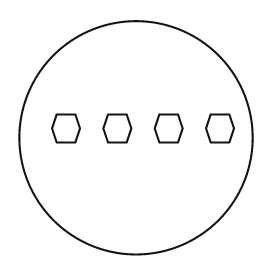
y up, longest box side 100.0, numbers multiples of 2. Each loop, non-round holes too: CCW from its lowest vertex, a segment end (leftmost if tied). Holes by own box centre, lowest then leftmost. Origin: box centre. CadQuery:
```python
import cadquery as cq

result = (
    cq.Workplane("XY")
    .moveTo(0.0, 0.0)
    .circle(50.0)
    .moveTo(-34.0, -2.0)
    .lineTo(-26.0, -2.0)
    .lineTo(-24.0, 4.0)
    .lineTo(-26.0, 10.0)
    .lineTo(-34.0, 10.0)
    .lineTo(-36.0, 4.0)
    .close()
    .moveTo(-12.0, -2.0)
    .lineTo(-4.0, -2.0)
    .lineTo(-2.0, 4.0)
    .lineTo(-4.0, 10.0)
    .lineTo(-12.0, 10.0)
    .lineTo(-14.0, 4.0)
    .close()
    .moveTo(10.0, -2.0)
    .lineTo(18.0, -2.0)
    .lineTo(20.0, 4.0)
    .lineTo(18.0, 10.0)
    .lineTo(10.0, 10.0)
    .lineTo(8.0, 4.0)
    .close()
    .moveTo(32.0, -2.0)
    .lineTo(40.0, -2.0)
    .lineTo(42.0, 4.0)
    .lineTo(40.0, 10.0)
    .lineTo(32.0, 10.0)
    .lineTo(30.0, 4.0)
    .close()
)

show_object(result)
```